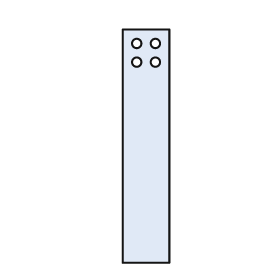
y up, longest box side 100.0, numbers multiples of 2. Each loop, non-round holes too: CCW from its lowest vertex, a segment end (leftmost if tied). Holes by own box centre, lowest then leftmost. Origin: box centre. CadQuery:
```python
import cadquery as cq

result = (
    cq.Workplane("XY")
    .moveTo(-10.0, -50.0)
    .lineTo(10.0, -50.0)
    .lineTo(10.0, 50.0)
    .lineTo(-10.0, 50.0)
    .close()
    .moveTo(-4.0, 36.0)
    .circle(2.0)
    .moveTo(4.0, 36.0)
    .circle(2.0)
    .moveTo(-4.0, 44.0)
    .circle(2.0)
    .moveTo(4.0, 44.0)
    .circle(2.0)
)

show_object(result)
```